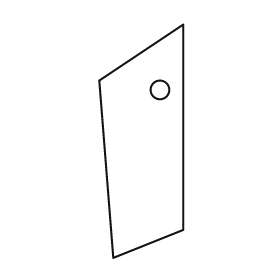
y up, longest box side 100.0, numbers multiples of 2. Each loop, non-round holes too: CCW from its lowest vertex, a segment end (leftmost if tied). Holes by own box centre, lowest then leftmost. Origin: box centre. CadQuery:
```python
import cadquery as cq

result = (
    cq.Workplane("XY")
    .moveTo(-12.0, -50.0)
    .lineTo(18.0, -38.0)
    .lineTo(18.0, 50.0)
    .lineTo(-18.0, 26.0)
    .close()
    .moveTo(8.0, 22.0)
    .circle(4.0)
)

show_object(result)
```